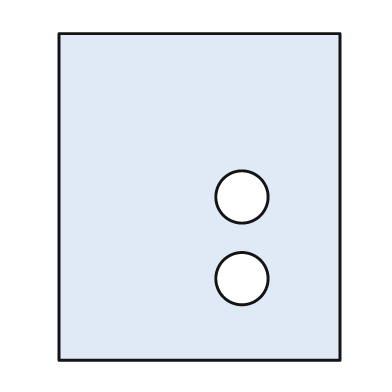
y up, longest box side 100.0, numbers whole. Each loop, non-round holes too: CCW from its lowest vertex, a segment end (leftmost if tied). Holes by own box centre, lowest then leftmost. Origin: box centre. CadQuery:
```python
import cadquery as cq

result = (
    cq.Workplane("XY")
    .moveTo(-43.0, -50.0)
    .lineTo(43.0, -50.0)
    .lineTo(43.0, 50.0)
    .lineTo(-43.0, 50.0)
    .close()
    .moveTo(13.0, -25.0)
    .circle(8.0)
    .moveTo(13.0, 0.0)
    .circle(8.0)
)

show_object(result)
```